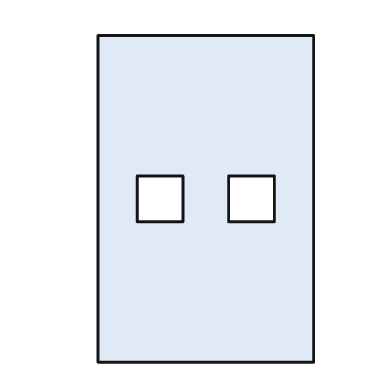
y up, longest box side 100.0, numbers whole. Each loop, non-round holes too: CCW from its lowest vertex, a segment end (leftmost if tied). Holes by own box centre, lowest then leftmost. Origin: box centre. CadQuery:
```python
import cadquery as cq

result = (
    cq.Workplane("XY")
    .moveTo(-33.0, -50.0)
    .lineTo(33.0, -50.0)
    .lineTo(33.0, 50.0)
    .lineTo(-33.0, 50.0)
    .close()
    .moveTo(-21.0, -7.0)
    .lineTo(-7.0, -7.0)
    .lineTo(-7.0, 7.0)
    .lineTo(-21.0, 7.0)
    .close()
    .moveTo(7.0, -7.0)
    .lineTo(21.0, -7.0)
    .lineTo(21.0, 7.0)
    .lineTo(7.0, 7.0)
    .close()
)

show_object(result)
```